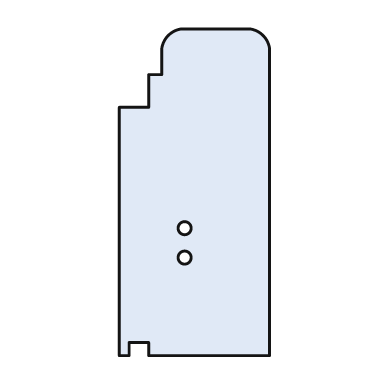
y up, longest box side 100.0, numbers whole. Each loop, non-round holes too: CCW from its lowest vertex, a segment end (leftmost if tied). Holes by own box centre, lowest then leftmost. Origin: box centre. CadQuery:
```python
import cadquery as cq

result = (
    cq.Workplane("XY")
    .moveTo(-23.0, -50.0)
    .lineTo(-20.0, -50.0)
    .lineTo(-20.0, -46.0)
    .lineTo(-14.0, -46.0)
    .lineTo(-14.0, -50.0)
    .lineTo(23.0, -50.0)
    .lineTo(23.0, 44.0)
    .threePointArc((21.0, 48.0), (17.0, 50.0))
    .lineTo(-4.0, 50.0)
    .threePointArc((-8.0, 48.0), (-10.0, 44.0))
    .lineTo(-10.0, 36.0)
    .lineTo(-14.0, 36.0)
    .lineTo(-14.0, 26.0)
    .lineTo(-23.0, 26.0)
    .close()
    .moveTo(-3.0, -20.0)
    .circle(2.0)
    .moveTo(-3.0, -11.0)
    .circle(2.0)
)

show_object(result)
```